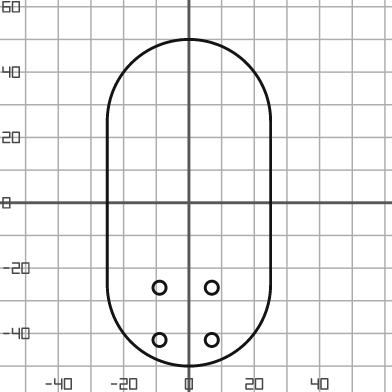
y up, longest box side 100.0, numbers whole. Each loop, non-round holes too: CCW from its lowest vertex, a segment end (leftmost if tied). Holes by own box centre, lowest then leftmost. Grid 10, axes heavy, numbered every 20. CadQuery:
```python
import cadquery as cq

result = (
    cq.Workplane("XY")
    .moveTo(-25.0, -25.0)
    .threePointArc((0.0, -50.0), (25.0, -25.0))
    .lineTo(25.0, 25.0)
    .threePointArc((0.0, 50.0), (-25.0, 25.0))
    .close()
    .moveTo(-9.0, -42.0)
    .circle(2.0)
    .moveTo(7.0, -42.0)
    .circle(2.0)
    .moveTo(-9.0, -26.0)
    .circle(2.0)
    .moveTo(7.0, -26.0)
    .circle(2.0)
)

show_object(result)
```